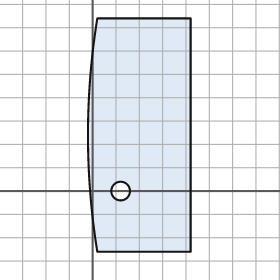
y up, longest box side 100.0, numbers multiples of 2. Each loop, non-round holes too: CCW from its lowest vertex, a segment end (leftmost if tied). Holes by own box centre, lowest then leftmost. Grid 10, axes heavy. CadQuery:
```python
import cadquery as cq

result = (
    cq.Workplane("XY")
    .moveTo(2.0, -26.0)
    .lineTo(42.0, -26.0)
    .lineTo(42.0, 74.0)
    .lineTo(2.0, 74.0)
    .threePointArc((-2.0, 24.0), (2.0, -26.0))
    .close()
    .moveTo(12.0, 0.0)
    .circle(4.0)
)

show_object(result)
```